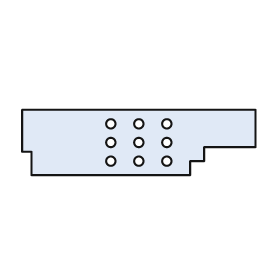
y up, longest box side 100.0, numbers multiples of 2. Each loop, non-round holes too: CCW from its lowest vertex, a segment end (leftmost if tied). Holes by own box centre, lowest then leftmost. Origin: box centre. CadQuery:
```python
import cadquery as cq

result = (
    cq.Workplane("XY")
    .moveTo(-46.0, -14.0)
    .lineTo(22.0, -14.0)
    .lineTo(22.0, -8.0)
    .lineTo(28.0, -8.0)
    .lineTo(28.0, -2.0)
    .lineTo(50.0, -2.0)
    .lineTo(50.0, 14.0)
    .lineTo(-50.0, 14.0)
    .lineTo(-50.0, -4.0)
    .lineTo(-46.0, -4.0)
    .close()
    .moveTo(-12.0, -8.0)
    .circle(2.0)
    .moveTo(0.0, -8.0)
    .circle(2.0)
    .moveTo(12.0, -8.0)
    .circle(2.0)
    .moveTo(-12.0, 0.0)
    .circle(2.0)
    .moveTo(0.0, 0.0)
    .circle(2.0)
    .moveTo(12.0, 0.0)
    .circle(2.0)
    .moveTo(-12.0, 8.0)
    .circle(2.0)
    .moveTo(0.0, 8.0)
    .circle(2.0)
    .moveTo(12.0, 8.0)
    .circle(2.0)
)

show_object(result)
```